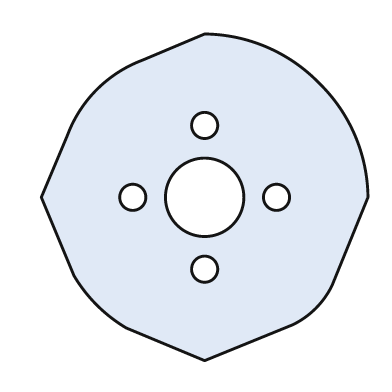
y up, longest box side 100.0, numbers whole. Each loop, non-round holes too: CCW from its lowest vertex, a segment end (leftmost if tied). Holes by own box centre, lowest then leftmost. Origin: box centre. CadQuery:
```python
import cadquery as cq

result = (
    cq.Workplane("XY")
    .moveTo(0.0, -50.0)
    .lineTo(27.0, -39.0)
    .threePointArc((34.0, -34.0), (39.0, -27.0))
    .lineTo(50.0, 0.0)
    .threePointArc((46.0, 19.0), (35.0, 35.0))
    .threePointArc((19.0, 46.0), (0.0, 50.0))
    .lineTo(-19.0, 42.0)
    .threePointArc((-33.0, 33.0), (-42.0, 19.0))
    .lineTo(-50.0, 0.0)
    .lineTo(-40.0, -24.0)
    .threePointArc((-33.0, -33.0), (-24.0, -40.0))
    .close()
    .moveTo(0.0, -22.0)
    .circle(4.0)
    .moveTo(-22.0, 0.0)
    .circle(4.0)
    .moveTo(0.0, 0.0)
    .circle(12.0)
    .moveTo(22.0, 0.0)
    .circle(4.0)
    .moveTo(0.0, 22.0)
    .circle(4.0)
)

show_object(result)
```